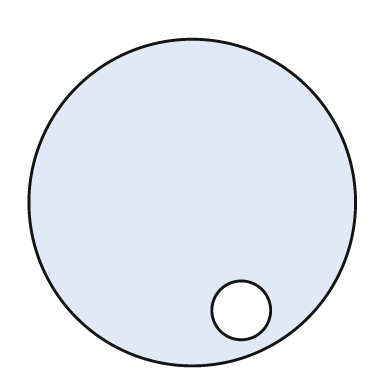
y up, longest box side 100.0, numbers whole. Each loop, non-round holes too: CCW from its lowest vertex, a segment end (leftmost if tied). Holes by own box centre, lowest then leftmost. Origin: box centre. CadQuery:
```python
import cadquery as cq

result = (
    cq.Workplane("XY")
    .moveTo(0.0, 0.0)
    .circle(50.0)
    .moveTo(15.0, -33.0)
    .circle(9.0)
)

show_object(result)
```